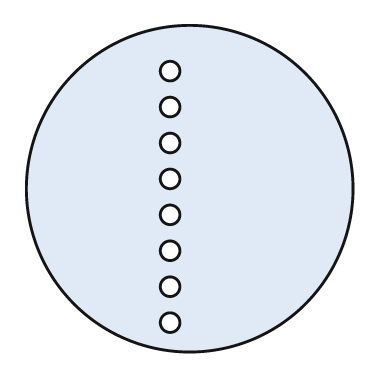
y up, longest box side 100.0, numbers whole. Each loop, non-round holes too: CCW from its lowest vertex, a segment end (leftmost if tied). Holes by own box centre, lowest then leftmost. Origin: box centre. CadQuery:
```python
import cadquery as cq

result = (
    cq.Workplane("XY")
    .moveTo(0.0, 0.0)
    .circle(50.0)
    .moveTo(-6.0, -41.0)
    .circle(3.0)
    .moveTo(-6.0, -30.0)
    .circle(3.0)
    .moveTo(-6.0, -19.0)
    .circle(3.0)
    .moveTo(-6.0, -8.0)
    .circle(3.0)
    .moveTo(-6.0, 3.0)
    .circle(3.0)
    .moveTo(-6.0, 14.0)
    .circle(3.0)
    .moveTo(-6.0, 25.0)
    .circle(3.0)
    .moveTo(-6.0, 36.0)
    .circle(3.0)
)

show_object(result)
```